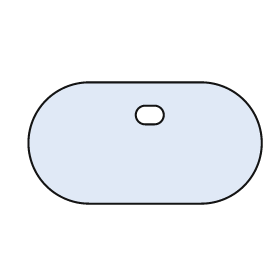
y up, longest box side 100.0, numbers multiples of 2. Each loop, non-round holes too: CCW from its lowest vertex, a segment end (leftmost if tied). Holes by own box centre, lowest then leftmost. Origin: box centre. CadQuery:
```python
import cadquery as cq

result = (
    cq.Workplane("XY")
    .moveTo(-24.0, -26.0)
    .lineTo(24.0, -26.0)
    .threePointArc((50.0, 0.0), (24.0, 26.0))
    .lineTo(-24.0, 26.0)
    .threePointArc((-50.0, 0.0), (-24.0, -26.0))
    .close()
    .moveTo(0.0, 8.0)
    .lineTo(4.0, 8.0)
    .threePointArc((8.0, 12.0), (4.0, 16.0))
    .lineTo(0.0, 16.0)
    .threePointArc((-4.0, 12.0), (0.0, 8.0))
    .close()
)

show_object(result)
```